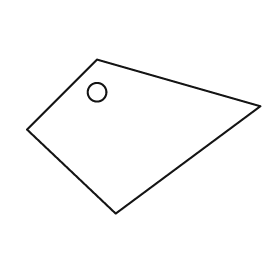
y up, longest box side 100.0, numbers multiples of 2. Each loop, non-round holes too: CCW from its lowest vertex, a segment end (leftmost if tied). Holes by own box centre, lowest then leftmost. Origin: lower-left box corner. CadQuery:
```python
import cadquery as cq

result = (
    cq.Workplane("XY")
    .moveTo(38.0, 0.0)
    .lineTo(100.0, 46.0)
    .lineTo(30.0, 66.0)
    .lineTo(0.0, 36.0)
    .close()
    .moveTo(30.0, 52.0)
    .circle(4.0)
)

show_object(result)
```